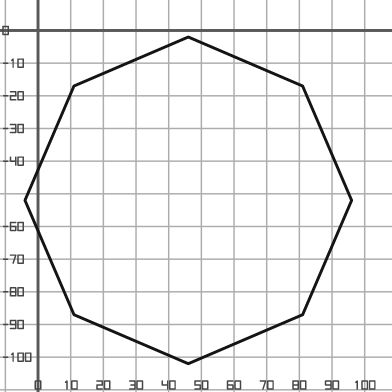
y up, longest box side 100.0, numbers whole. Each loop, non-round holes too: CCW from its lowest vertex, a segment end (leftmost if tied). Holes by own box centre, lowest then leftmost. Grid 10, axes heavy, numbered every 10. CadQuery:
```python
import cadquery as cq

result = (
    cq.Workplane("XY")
    .moveTo(46.0, -102.0)
    .lineTo(81.0, -87.0)
    .lineTo(96.0, -52.0)
    .lineTo(81.0, -17.0)
    .lineTo(46.0, -2.0)
    .lineTo(11.0, -17.0)
    .lineTo(-4.0, -52.0)
    .lineTo(11.0, -87.0)
    .close()
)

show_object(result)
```